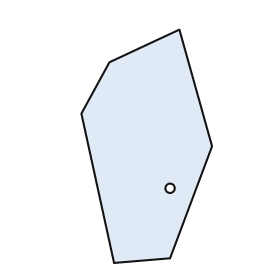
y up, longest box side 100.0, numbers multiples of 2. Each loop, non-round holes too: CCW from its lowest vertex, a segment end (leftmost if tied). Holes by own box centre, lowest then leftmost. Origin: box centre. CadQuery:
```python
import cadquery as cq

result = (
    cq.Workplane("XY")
    .moveTo(-14.0, -50.0)
    .lineTo(10.0, -48.0)
    .lineTo(28.0, 0.0)
    .lineTo(14.0, 50.0)
    .lineTo(-16.0, 36.0)
    .lineTo(-28.0, 14.0)
    .close()
    .moveTo(10.0, -18.0)
    .circle(2.0)
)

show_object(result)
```